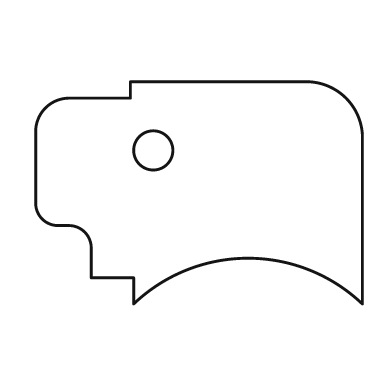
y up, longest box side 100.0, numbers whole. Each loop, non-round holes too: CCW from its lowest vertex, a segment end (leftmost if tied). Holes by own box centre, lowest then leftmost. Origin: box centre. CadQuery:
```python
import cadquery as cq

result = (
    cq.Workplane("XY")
    .moveTo(-20.0, -34.0)
    .threePointArc((15.0, -20.0), (50.0, -34.0))
    .lineTo(50.0, 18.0)
    .threePointArc((45.0, 29.0), (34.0, 34.0))
    .lineTo(-21.0, 34.0)
    .lineTo(-21.0, 29.0)
    .lineTo(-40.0, 29.0)
    .threePointArc((-47.0, 26.0), (-50.0, 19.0))
    .lineTo(-50.0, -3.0)
    .threePointArc((-48.0, -8.0), (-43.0, -10.0))
    .lineTo(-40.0, -10.0)
    .threePointArc((-35.0, -12.0), (-33.0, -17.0))
    .lineTo(-33.0, -26.0)
    .lineTo(-20.0, -26.0)
    .close()
    .moveTo(-14.0, 13.0)
    .circle(6.0)
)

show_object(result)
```